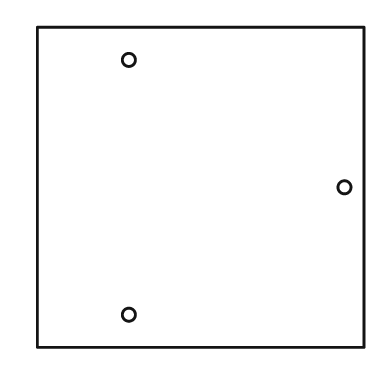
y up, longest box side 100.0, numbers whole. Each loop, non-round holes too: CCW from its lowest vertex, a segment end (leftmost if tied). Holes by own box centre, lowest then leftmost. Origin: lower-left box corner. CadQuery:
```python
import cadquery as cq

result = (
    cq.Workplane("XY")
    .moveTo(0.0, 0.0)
    .lineTo(100.0, 0.0)
    .lineTo(100.0, 98.0)
    .lineTo(0.0, 98.0)
    .close()
    .moveTo(28.0, 10.0)
    .circle(2.0)
    .moveTo(94.0, 49.0)
    .circle(2.0)
    .moveTo(28.0, 88.0)
    .circle(2.0)
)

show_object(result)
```